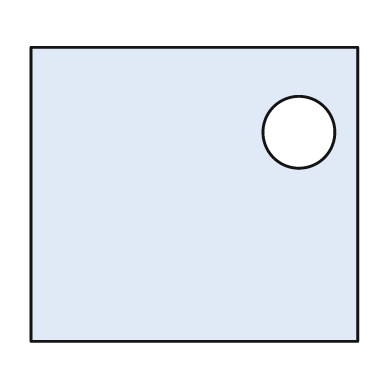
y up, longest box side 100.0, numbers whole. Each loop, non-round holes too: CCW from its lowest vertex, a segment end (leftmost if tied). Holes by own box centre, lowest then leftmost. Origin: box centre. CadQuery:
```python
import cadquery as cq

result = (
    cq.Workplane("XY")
    .moveTo(-50.0, -45.0)
    .lineTo(50.0, -45.0)
    .lineTo(50.0, 45.0)
    .lineTo(-50.0, 45.0)
    .close()
    .moveTo(32.0, 19.0)
    .circle(11.0)
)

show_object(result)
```